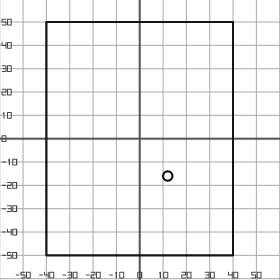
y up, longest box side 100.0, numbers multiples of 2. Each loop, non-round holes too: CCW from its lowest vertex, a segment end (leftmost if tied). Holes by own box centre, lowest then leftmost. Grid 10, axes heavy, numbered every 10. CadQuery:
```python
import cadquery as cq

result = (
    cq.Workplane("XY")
    .moveTo(-40.0, -50.0)
    .lineTo(40.0, -50.0)
    .lineTo(40.0, 50.0)
    .lineTo(-40.0, 50.0)
    .close()
    .moveTo(12.0, -16.0)
    .circle(2.0)
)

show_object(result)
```